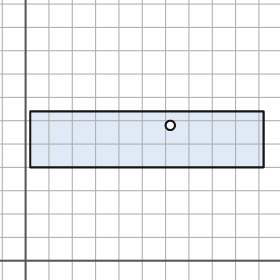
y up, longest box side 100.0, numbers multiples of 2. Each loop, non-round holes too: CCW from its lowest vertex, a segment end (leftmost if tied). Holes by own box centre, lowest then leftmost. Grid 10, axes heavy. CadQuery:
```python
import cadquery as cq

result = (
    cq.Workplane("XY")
    .moveTo(2.0, 40.0)
    .lineTo(102.0, 40.0)
    .lineTo(102.0, 64.0)
    .lineTo(2.0, 64.0)
    .close()
    .moveTo(62.0, 58.0)
    .circle(2.0)
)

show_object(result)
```